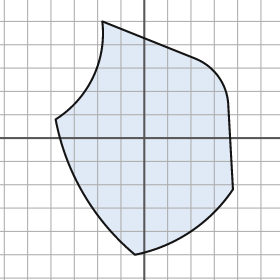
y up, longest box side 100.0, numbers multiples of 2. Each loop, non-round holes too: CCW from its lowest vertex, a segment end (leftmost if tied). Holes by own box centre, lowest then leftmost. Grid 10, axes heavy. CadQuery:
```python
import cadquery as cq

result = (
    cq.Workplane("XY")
    .moveTo(-4.0, -50.0)
    .threePointArc((20.0, -40.0), (38.0, -22.0))
    .lineTo(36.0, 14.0)
    .threePointArc((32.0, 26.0), (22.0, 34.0))
    .lineTo(-18.0, 50.0)
    .threePointArc((-22.0, 26.0), (-38.0, 8.0))
    .threePointArc((-26.0, -24.0), (-4.0, -50.0))
    .close()
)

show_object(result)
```